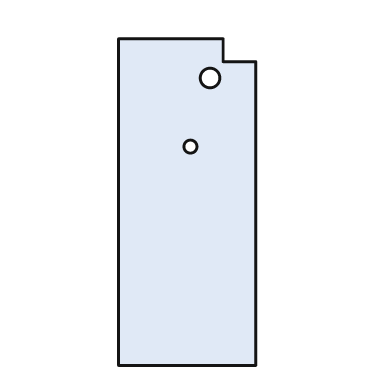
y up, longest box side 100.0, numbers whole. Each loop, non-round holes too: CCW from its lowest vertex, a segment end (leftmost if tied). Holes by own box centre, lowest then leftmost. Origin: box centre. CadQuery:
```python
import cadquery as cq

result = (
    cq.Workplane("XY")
    .moveTo(-21.0, -50.0)
    .lineTo(21.0, -50.0)
    .lineTo(21.0, 43.0)
    .lineTo(11.0, 43.0)
    .lineTo(11.0, 50.0)
    .lineTo(-21.0, 50.0)
    .close()
    .moveTo(1.0, 17.0)
    .circle(2.0)
    .moveTo(7.0, 38.0)
    .circle(3.0)
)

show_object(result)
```